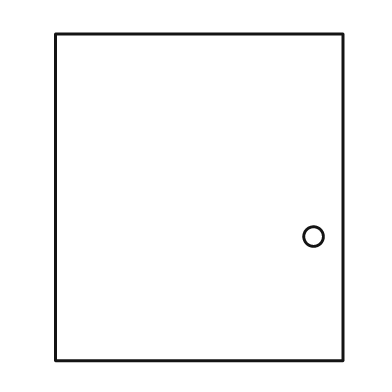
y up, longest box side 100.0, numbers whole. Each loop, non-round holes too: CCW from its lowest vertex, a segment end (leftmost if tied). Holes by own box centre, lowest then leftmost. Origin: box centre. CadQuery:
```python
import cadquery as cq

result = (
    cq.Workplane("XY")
    .moveTo(-44.0, -50.0)
    .lineTo(44.0, -50.0)
    .lineTo(44.0, 50.0)
    .lineTo(-44.0, 50.0)
    .close()
    .moveTo(35.0, -12.0)
    .circle(3.0)
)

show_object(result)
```